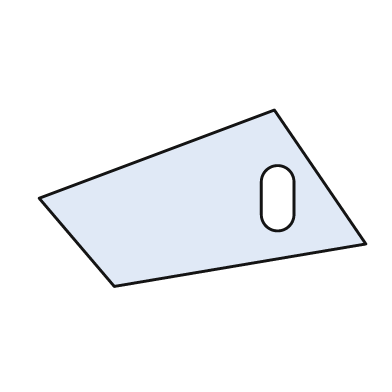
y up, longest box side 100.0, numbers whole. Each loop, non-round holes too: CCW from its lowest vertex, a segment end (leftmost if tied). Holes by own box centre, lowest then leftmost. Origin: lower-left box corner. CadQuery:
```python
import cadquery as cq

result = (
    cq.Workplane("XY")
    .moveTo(23.0, 0.0)
    .lineTo(100.0, 13.0)
    .lineTo(72.0, 54.0)
    .lineTo(0.0, 27.0)
    .close()
    .moveTo(68.0, 22.0)
    .threePointArc((73.0, 17.0), (78.0, 22.0))
    .lineTo(78.0, 32.0)
    .threePointArc((73.0, 37.0), (68.0, 32.0))
    .close()
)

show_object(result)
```